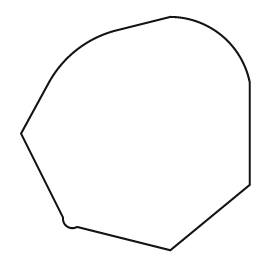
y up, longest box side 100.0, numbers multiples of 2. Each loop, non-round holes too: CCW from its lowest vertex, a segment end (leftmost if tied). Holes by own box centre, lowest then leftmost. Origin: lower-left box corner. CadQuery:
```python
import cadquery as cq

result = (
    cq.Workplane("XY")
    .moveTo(64.0, 0.0)
    .lineTo(98.0, 28.0)
    .lineTo(98.0, 72.0)
    .threePointArc((86.0, 92.0), (64.0, 100.0))
    .lineTo(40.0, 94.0)
    .threePointArc((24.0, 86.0), (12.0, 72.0))
    .lineTo(0.0, 50.0)
    .lineTo(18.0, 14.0)
    .threePointArc((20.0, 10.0), (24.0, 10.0))
    .close()
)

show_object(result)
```